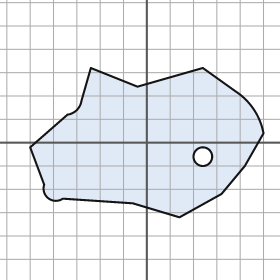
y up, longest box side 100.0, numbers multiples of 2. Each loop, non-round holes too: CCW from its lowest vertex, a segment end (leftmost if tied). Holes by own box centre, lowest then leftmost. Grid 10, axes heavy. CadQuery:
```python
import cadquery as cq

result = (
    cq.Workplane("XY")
    .moveTo(14.0, -32.0)
    .lineTo(32.0, -22.0)
    .lineTo(42.0, -10.0)
    .lineTo(50.0, 4.0)
    .threePointArc((46.0, 14.0), (38.0, 22.0))
    .lineTo(24.0, 32.0)
    .lineTo(-4.0, 24.0)
    .lineTo(-24.0, 32.0)
    .lineTo(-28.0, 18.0)
    .threePointArc((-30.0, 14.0), (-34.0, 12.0))
    .lineTo(-50.0, -2.0)
    .lineTo(-44.0, -18.0)
    .threePointArc((-42.0, -24.0), (-36.0, -24.0))
    .lineTo(-6.0, -26.0)
    .close()
    .moveTo(24.0, -6.0)
    .circle(4.0)
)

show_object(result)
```